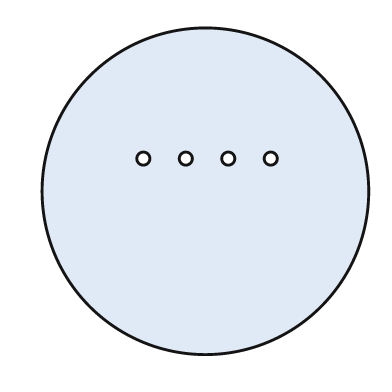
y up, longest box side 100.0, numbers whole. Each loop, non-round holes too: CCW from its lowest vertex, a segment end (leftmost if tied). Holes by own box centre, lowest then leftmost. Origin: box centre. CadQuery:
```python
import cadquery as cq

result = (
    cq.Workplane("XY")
    .moveTo(0.0, 0.0)
    .circle(50.0)
    .moveTo(-19.0, 10.0)
    .circle(2.0)
    .moveTo(-6.0, 10.0)
    .circle(2.0)
    .moveTo(7.0, 10.0)
    .circle(2.0)
    .moveTo(20.0, 10.0)
    .circle(2.0)
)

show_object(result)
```